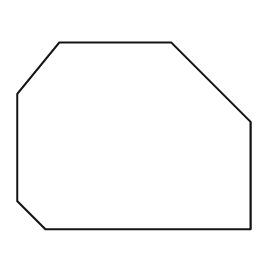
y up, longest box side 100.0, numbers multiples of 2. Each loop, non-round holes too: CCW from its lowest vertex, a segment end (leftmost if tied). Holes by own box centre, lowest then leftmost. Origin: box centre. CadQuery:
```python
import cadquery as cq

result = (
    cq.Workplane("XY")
    .moveTo(-38.0, -40.0)
    .lineTo(50.0, -40.0)
    .lineTo(50.0, 6.0)
    .lineTo(16.0, 40.0)
    .lineTo(-32.0, 40.0)
    .lineTo(-50.0, 18.0)
    .lineTo(-50.0, -28.0)
    .close()
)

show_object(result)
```